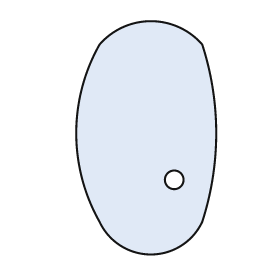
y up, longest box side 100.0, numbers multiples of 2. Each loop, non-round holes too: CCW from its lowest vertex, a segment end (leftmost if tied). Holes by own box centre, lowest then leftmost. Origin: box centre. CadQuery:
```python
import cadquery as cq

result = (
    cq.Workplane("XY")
    .moveTo(-20.0, -36.0)
    .threePointArc((2.0, -50.0), (24.0, -36.0))
    .threePointArc((30.0, 2.0), (24.0, 40.0))
    .threePointArc((2.0, 50.0), (-20.0, 40.0))
    .threePointArc((-30.0, 2.0), (-20.0, -36.0))
    .close()
    .moveTo(12.0, -18.0)
    .circle(4.0)
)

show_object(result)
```